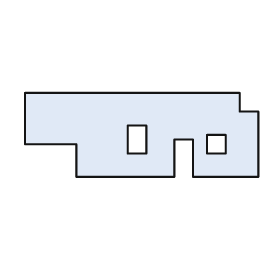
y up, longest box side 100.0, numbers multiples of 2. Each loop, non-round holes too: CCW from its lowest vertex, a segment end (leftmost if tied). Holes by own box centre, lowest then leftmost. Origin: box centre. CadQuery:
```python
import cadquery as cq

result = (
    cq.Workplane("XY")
    .moveTo(-28.0, -18.0)
    .lineTo(14.0, -18.0)
    .lineTo(14.0, -2.0)
    .lineTo(22.0, -2.0)
    .lineTo(22.0, -18.0)
    .lineTo(50.0, -18.0)
    .lineTo(50.0, 10.0)
    .lineTo(42.0, 10.0)
    .lineTo(42.0, 18.0)
    .lineTo(-50.0, 18.0)
    .lineTo(-50.0, -4.0)
    .lineTo(-28.0, -4.0)
    .close()
    .moveTo(28.0, -8.0)
    .lineTo(36.0, -8.0)
    .lineTo(36.0, 0.0)
    .lineTo(28.0, 0.0)
    .close()
    .moveTo(-6.0, -8.0)
    .lineTo(2.0, -8.0)
    .lineTo(2.0, 4.0)
    .lineTo(-6.0, 4.0)
    .close()
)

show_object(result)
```